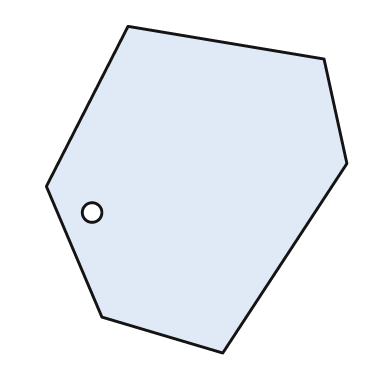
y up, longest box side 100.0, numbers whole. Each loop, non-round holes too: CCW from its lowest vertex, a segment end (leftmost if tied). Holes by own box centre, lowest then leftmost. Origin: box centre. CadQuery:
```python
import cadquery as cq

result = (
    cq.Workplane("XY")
    .moveTo(8.0, -50.0)
    .lineTo(46.0, 8.0)
    .lineTo(39.0, 40.0)
    .lineTo(-21.0, 50.0)
    .lineTo(-46.0, 1.0)
    .lineTo(-29.0, -39.0)
    .close()
    .moveTo(-32.0, -7.0)
    .circle(3.0)
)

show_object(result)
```